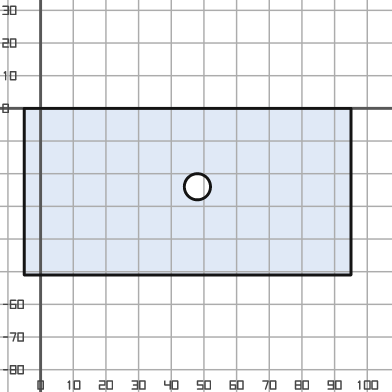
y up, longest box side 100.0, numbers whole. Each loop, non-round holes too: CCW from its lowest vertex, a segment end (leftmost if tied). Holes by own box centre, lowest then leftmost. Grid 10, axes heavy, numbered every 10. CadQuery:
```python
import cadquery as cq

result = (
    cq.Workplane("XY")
    .moveTo(-5.0, -51.0)
    .lineTo(95.0, -51.0)
    .lineTo(95.0, 0.0)
    .lineTo(-5.0, 0.0)
    .close()
    .moveTo(48.0, -24.0)
    .circle(4.0)
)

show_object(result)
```